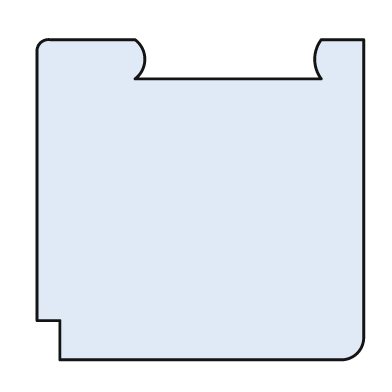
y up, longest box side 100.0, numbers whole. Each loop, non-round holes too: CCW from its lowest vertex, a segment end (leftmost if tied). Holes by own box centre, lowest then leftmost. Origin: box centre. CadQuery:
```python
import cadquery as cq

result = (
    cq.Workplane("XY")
    .moveTo(-43.0, -49.0)
    .lineTo(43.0, -49.0)
    .threePointArc((48.0, -47.0), (50.0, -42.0))
    .lineTo(50.0, 49.0)
    .lineTo(37.0, 49.0)
    .threePointArc((35.0, 43.0), (37.0, 37.0))
    .lineTo(-20.0, 37.0)
    .threePointArc((-17.0, 43.0), (-20.0, 49.0))
    .lineTo(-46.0, 49.0)
    .threePointArc((-49.0, 48.0), (-50.0, 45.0))
    .lineTo(-50.0, -37.0)
    .lineTo(-43.0, -37.0)
    .close()
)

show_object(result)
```